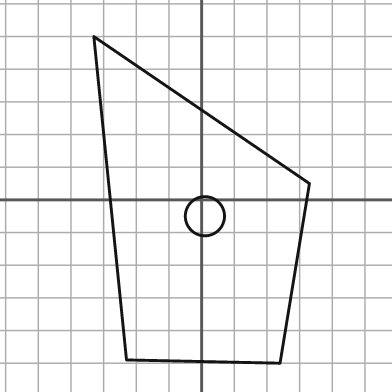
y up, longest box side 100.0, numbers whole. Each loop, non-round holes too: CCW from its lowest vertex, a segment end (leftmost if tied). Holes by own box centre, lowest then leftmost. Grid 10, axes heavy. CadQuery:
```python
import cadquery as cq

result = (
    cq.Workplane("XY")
    .moveTo(24.0, -50.0)
    .lineTo(33.0, 5.0)
    .lineTo(-33.0, 50.0)
    .lineTo(-23.0, -49.0)
    .close()
    .moveTo(1.0, -5.0)
    .circle(6.0)
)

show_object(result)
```